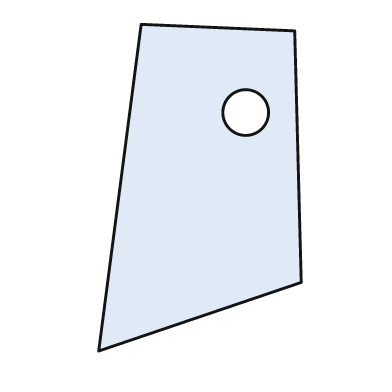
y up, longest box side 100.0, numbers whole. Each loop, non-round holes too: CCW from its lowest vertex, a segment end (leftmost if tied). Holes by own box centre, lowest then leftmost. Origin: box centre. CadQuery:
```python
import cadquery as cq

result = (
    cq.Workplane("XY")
    .moveTo(-31.0, -50.0)
    .lineTo(31.0, -29.0)
    .lineTo(29.0, 48.0)
    .lineTo(-18.0, 50.0)
    .close()
    .moveTo(14.0, 23.0)
    .circle(7.0)
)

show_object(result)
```